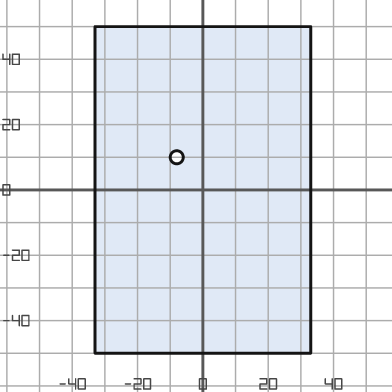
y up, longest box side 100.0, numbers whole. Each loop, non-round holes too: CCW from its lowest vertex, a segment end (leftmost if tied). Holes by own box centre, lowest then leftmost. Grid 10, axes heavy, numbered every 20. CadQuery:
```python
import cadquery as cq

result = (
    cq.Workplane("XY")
    .moveTo(-33.0, -50.0)
    .lineTo(33.0, -50.0)
    .lineTo(33.0, 50.0)
    .lineTo(-33.0, 50.0)
    .close()
    .moveTo(-8.0, 10.0)
    .circle(2.0)
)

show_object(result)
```